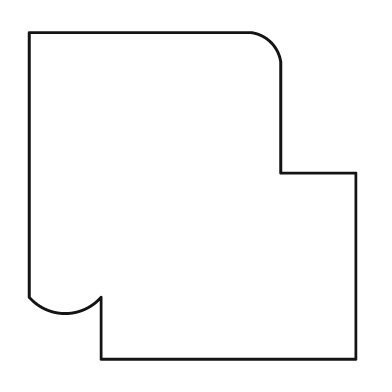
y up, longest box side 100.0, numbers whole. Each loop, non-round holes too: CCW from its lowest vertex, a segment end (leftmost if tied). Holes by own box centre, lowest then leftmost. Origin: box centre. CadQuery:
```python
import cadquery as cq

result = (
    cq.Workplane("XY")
    .moveTo(-28.0, -50.0)
    .lineTo(50.0, -50.0)
    .lineTo(50.0, 7.0)
    .lineTo(27.0, 7.0)
    .lineTo(27.0, 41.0)
    .threePointArc((24.0, 47.0), (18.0, 50.0))
    .lineTo(-50.0, 50.0)
    .lineTo(-50.0, -31.0)
    .threePointArc((-39.0, -36.0), (-28.0, -31.0))
    .close()
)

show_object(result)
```